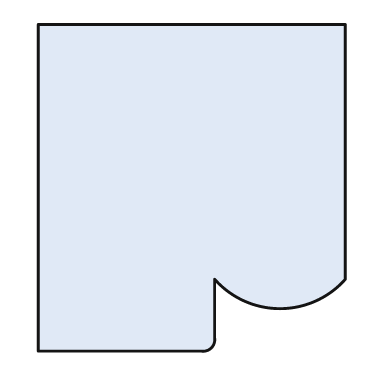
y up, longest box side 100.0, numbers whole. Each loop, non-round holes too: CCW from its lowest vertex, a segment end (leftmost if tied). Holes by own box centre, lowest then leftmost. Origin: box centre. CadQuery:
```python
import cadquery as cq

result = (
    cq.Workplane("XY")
    .moveTo(-47.0, -50.0)
    .lineTo(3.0, -50.0)
    .threePointArc((6.0, -49.0), (7.0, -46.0))
    .lineTo(7.0, -28.0)
    .threePointArc((27.0, -37.0), (47.0, -28.0))
    .lineTo(47.0, 50.0)
    .lineTo(-47.0, 50.0)
    .close()
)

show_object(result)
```